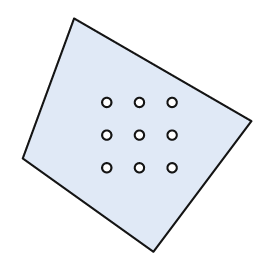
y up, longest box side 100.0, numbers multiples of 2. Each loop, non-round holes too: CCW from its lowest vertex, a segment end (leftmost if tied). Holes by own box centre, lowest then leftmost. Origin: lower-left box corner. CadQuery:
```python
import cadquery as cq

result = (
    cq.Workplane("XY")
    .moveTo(56.0, 0.0)
    .lineTo(98.0, 56.0)
    .lineTo(22.0, 100.0)
    .lineTo(0.0, 40.0)
    .close()
    .moveTo(36.0, 36.0)
    .circle(2.0)
    .moveTo(50.0, 36.0)
    .circle(2.0)
    .moveTo(64.0, 36.0)
    .circle(2.0)
    .moveTo(36.0, 50.0)
    .circle(2.0)
    .moveTo(50.0, 50.0)
    .circle(2.0)
    .moveTo(64.0, 50.0)
    .circle(2.0)
    .moveTo(36.0, 64.0)
    .circle(2.0)
    .moveTo(50.0, 64.0)
    .circle(2.0)
    .moveTo(64.0, 64.0)
    .circle(2.0)
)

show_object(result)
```